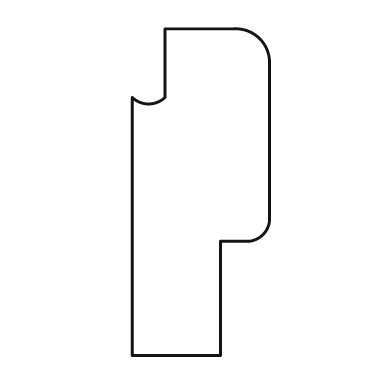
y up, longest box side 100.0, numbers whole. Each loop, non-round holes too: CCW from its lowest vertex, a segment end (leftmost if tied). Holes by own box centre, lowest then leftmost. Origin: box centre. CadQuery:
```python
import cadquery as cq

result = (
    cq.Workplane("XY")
    .moveTo(-21.0, -50.0)
    .lineTo(6.0, -50.0)
    .lineTo(6.0, -15.0)
    .lineTo(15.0, -15.0)
    .threePointArc((19.0, -13.0), (21.0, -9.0))
    .lineTo(21.0, 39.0)
    .threePointArc((18.0, 47.0), (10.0, 50.0))
    .lineTo(-11.0, 50.0)
    .lineTo(-11.0, 29.0)
    .threePointArc((-16.0, 27.0), (-21.0, 29.0))
    .close()
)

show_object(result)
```